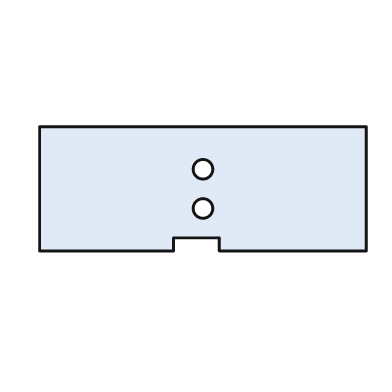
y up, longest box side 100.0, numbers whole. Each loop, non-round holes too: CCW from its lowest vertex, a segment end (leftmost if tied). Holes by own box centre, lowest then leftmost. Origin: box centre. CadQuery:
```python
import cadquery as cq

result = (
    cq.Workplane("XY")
    .moveTo(-50.0, -19.0)
    .lineTo(-9.0, -19.0)
    .lineTo(-9.0, -15.0)
    .lineTo(5.0, -15.0)
    .lineTo(5.0, -19.0)
    .lineTo(50.0, -19.0)
    .lineTo(50.0, 19.0)
    .lineTo(-50.0, 19.0)
    .close()
    .moveTo(0.0, -6.0)
    .circle(3.0)
    .moveTo(0.0, 6.0)
    .circle(3.0)
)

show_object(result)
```